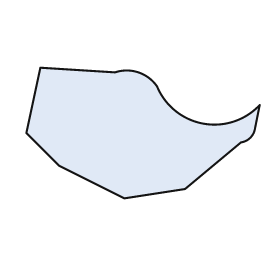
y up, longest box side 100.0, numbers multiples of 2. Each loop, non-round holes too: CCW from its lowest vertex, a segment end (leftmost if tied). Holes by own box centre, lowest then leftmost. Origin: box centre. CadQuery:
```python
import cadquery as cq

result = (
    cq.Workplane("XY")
    .moveTo(-8.0, -28.0)
    .lineTo(18.0, -24.0)
    .lineTo(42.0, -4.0)
    .threePointArc((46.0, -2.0), (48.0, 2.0))
    .lineTo(50.0, 12.0)
    .threePointArc((26.0, 4.0), (6.0, 20.0))
    .threePointArc((-2.0, 26.0), (-12.0, 26.0))
    .lineTo(-44.0, 28.0)
    .lineTo(-50.0, 0.0)
    .lineTo(-36.0, -14.0)
    .close()
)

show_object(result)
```